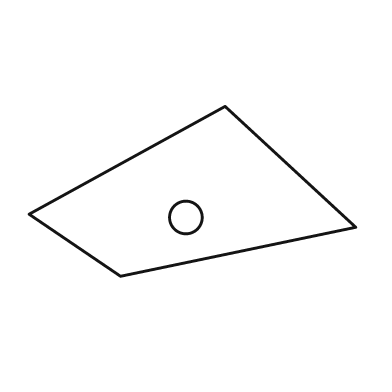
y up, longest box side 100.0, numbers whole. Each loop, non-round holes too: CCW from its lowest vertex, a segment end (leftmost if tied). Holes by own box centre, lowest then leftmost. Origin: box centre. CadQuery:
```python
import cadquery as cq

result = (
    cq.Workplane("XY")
    .moveTo(-22.0, -26.0)
    .lineTo(50.0, -11.0)
    .lineTo(10.0, 26.0)
    .lineTo(-50.0, -7.0)
    .close()
    .moveTo(-2.0, -8.0)
    .circle(5.0)
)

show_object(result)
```